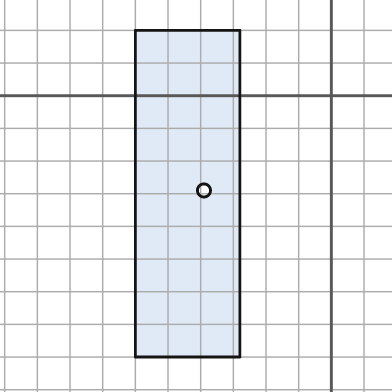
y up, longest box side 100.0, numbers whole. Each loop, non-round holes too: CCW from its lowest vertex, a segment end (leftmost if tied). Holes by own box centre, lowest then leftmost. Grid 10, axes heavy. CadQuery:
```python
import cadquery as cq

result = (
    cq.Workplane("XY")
    .moveTo(-60.0, -80.0)
    .lineTo(-28.0, -80.0)
    .lineTo(-28.0, 20.0)
    .lineTo(-60.0, 20.0)
    .close()
    .moveTo(-39.0, -29.0)
    .circle(2.0)
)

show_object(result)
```